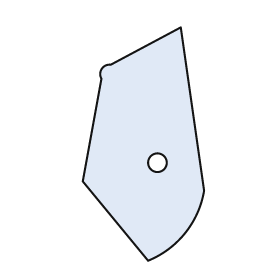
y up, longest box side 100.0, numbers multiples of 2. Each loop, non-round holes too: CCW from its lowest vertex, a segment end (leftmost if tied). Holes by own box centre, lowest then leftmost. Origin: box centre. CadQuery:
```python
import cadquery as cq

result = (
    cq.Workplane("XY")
    .moveTo(2.0, -50.0)
    .threePointArc((18.0, -38.0), (26.0, -20.0))
    .lineTo(16.0, 50.0)
    .lineTo(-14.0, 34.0)
    .threePointArc((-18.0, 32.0), (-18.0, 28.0))
    .lineTo(-26.0, -16.0)
    .close()
    .moveTo(6.0, -8.0)
    .circle(4.0)
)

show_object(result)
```